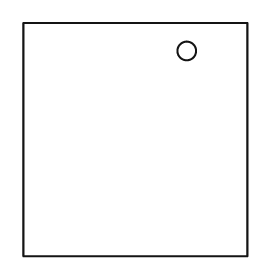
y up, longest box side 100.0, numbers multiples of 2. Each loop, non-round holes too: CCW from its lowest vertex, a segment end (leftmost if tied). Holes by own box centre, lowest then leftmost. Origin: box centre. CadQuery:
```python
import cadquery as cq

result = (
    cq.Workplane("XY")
    .moveTo(-48.0, -50.0)
    .lineTo(48.0, -50.0)
    .lineTo(48.0, 50.0)
    .lineTo(-48.0, 50.0)
    .close()
    .moveTo(22.0, 38.0)
    .circle(4.0)
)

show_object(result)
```